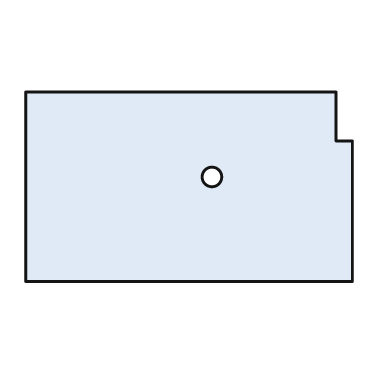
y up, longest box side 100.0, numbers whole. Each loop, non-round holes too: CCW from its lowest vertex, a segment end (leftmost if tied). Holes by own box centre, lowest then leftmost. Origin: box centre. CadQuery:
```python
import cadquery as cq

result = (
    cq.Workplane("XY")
    .moveTo(-50.0, -29.0)
    .lineTo(50.0, -29.0)
    .lineTo(50.0, 14.0)
    .lineTo(45.0, 14.0)
    .lineTo(45.0, 29.0)
    .lineTo(-50.0, 29.0)
    .close()
    .moveTo(7.0, 3.0)
    .circle(3.0)
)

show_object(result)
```